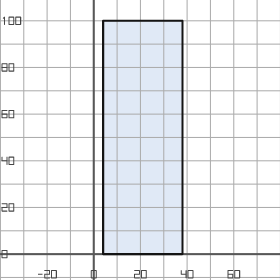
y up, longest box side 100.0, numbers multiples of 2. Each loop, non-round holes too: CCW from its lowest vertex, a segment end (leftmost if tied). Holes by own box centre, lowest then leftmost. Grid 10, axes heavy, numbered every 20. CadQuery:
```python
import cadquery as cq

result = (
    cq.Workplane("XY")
    .moveTo(4.0, 0.0)
    .lineTo(38.0, 0.0)
    .lineTo(38.0, 100.0)
    .lineTo(4.0, 100.0)
    .close()
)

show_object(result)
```